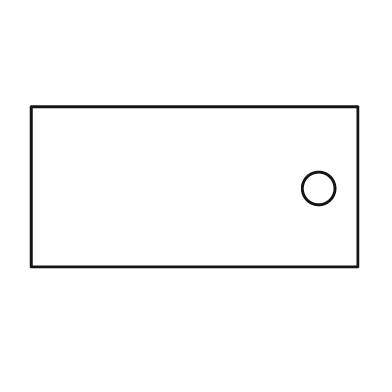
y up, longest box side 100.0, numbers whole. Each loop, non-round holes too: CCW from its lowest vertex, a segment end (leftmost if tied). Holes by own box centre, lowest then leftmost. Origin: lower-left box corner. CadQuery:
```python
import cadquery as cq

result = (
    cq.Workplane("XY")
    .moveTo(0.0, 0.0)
    .lineTo(100.0, 0.0)
    .lineTo(100.0, 49.0)
    .lineTo(0.0, 49.0)
    .close()
    .moveTo(88.0, 24.0)
    .circle(5.0)
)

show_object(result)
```